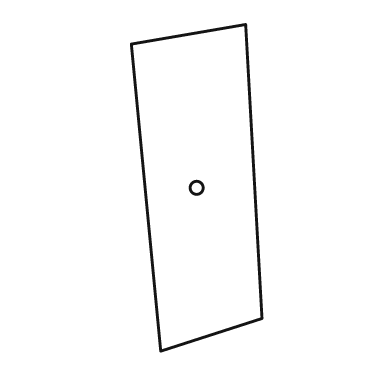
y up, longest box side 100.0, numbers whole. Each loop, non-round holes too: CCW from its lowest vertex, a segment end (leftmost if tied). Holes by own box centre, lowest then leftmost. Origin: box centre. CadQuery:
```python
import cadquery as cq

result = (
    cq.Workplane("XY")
    .moveTo(-11.0, -50.0)
    .lineTo(20.0, -40.0)
    .lineTo(15.0, 50.0)
    .lineTo(-20.0, 44.0)
    .close()
    .moveTo(0.0, 0.0)
    .circle(2.0)
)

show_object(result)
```